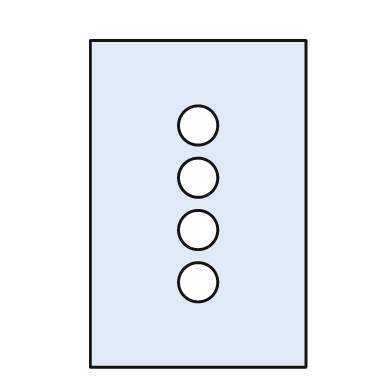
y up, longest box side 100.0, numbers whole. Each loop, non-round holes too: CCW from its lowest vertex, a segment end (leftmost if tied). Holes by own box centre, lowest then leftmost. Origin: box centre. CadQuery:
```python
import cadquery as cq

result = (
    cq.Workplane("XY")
    .moveTo(-33.0, -50.0)
    .lineTo(33.0, -50.0)
    .lineTo(33.0, 50.0)
    .lineTo(-33.0, 50.0)
    .close()
    .moveTo(0.0, -24.0)
    .circle(6.0)
    .moveTo(0.0, -8.0)
    .circle(6.0)
    .moveTo(0.0, 8.0)
    .circle(6.0)
    .moveTo(0.0, 24.0)
    .circle(6.0)
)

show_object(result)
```